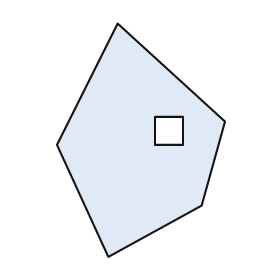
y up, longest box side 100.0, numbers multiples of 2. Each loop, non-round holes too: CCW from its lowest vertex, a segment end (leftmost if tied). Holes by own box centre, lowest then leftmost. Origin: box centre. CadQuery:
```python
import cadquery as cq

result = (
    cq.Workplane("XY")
    .moveTo(-14.0, -50.0)
    .lineTo(26.0, -28.0)
    .lineTo(36.0, 8.0)
    .lineTo(-10.0, 50.0)
    .lineTo(-36.0, -2.0)
    .close()
    .moveTo(6.0, -2.0)
    .lineTo(18.0, -2.0)
    .lineTo(18.0, 10.0)
    .lineTo(6.0, 10.0)
    .close()
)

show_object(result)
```